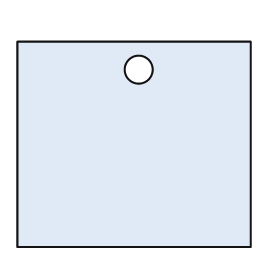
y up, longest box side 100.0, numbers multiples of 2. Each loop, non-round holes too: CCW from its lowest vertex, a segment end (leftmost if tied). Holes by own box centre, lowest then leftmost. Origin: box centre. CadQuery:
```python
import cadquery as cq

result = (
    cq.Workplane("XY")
    .moveTo(-50.0, -44.0)
    .lineTo(50.0, -44.0)
    .lineTo(50.0, 44.0)
    .lineTo(-50.0, 44.0)
    .close()
    .moveTo(2.0, 32.0)
    .circle(6.0)
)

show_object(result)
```